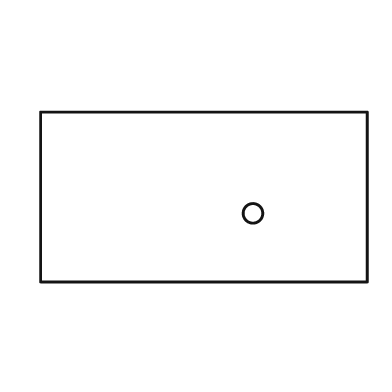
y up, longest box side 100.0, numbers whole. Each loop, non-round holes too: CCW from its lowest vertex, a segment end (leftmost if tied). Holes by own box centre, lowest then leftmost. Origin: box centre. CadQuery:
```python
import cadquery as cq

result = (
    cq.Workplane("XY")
    .moveTo(-50.0, -26.0)
    .lineTo(50.0, -26.0)
    .lineTo(50.0, 26.0)
    .lineTo(-50.0, 26.0)
    .close()
    .moveTo(15.0, -5.0)
    .circle(3.0)
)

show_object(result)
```